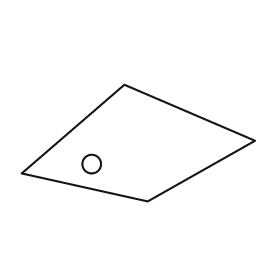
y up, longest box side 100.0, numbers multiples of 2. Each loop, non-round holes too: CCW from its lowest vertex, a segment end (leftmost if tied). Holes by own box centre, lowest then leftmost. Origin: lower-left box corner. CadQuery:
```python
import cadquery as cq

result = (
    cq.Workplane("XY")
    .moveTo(54.0, 0.0)
    .lineTo(100.0, 26.0)
    .lineTo(44.0, 50.0)
    .lineTo(0.0, 12.0)
    .close()
    .moveTo(30.0, 16.0)
    .circle(4.0)
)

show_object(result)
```